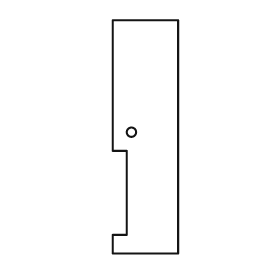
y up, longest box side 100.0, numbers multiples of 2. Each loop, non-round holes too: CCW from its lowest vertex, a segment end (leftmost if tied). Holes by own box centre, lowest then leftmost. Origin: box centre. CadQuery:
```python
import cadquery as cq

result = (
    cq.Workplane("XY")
    .moveTo(-14.0, -50.0)
    .lineTo(14.0, -50.0)
    .lineTo(14.0, 50.0)
    .lineTo(-14.0, 50.0)
    .lineTo(-14.0, -6.0)
    .lineTo(-8.0, -6.0)
    .lineTo(-8.0, -42.0)
    .lineTo(-14.0, -42.0)
    .close()
    .moveTo(-6.0, 2.0)
    .circle(2.0)
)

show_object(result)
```